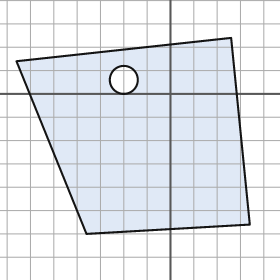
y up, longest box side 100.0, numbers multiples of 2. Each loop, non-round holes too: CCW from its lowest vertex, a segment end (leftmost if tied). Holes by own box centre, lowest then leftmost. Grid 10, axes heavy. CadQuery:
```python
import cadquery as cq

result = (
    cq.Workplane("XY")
    .moveTo(-36.0, -60.0)
    .lineTo(34.0, -56.0)
    .lineTo(26.0, 24.0)
    .lineTo(-66.0, 14.0)
    .close()
    .moveTo(-20.0, 6.0)
    .circle(6.0)
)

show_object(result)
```